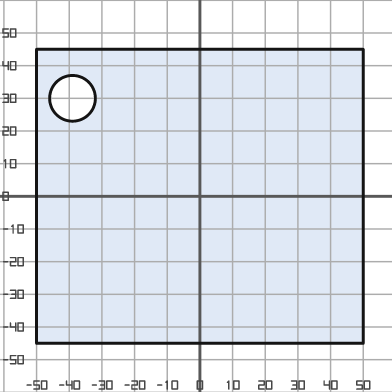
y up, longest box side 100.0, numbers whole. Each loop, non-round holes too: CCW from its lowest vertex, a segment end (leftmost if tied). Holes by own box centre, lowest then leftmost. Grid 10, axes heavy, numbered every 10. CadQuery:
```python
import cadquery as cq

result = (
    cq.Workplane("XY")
    .moveTo(-50.0, -45.0)
    .lineTo(50.0, -45.0)
    .lineTo(50.0, 45.0)
    .lineTo(-50.0, 45.0)
    .close()
    .moveTo(-39.0, 30.0)
    .circle(7.0)
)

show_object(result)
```